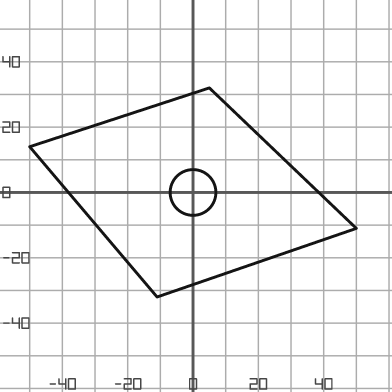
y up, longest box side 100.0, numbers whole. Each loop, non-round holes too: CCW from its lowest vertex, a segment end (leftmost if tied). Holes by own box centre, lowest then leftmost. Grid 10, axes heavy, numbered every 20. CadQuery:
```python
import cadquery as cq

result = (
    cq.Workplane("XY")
    .moveTo(-11.0, -32.0)
    .lineTo(50.0, -11.0)
    .lineTo(5.0, 32.0)
    .lineTo(-50.0, 14.0)
    .close()
    .moveTo(0.0, 0.0)
    .circle(7.0)
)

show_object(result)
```